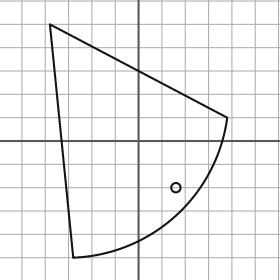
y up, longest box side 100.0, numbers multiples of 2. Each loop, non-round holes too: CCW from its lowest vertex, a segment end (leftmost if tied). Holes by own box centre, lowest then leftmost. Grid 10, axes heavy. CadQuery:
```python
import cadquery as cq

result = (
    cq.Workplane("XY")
    .moveTo(-28.0, -50.0)
    .threePointArc((16.0, -32.0), (38.0, 10.0))
    .lineTo(-38.0, 50.0)
    .close()
    .moveTo(16.0, -20.0)
    .circle(2.0)
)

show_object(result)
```